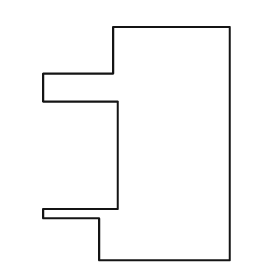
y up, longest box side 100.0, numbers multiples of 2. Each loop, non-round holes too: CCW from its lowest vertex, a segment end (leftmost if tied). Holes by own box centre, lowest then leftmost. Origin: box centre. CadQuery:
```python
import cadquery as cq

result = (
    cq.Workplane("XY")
    .moveTo(-16.0, -50.0)
    .lineTo(40.0, -50.0)
    .lineTo(40.0, 50.0)
    .lineTo(-10.0, 50.0)
    .lineTo(-10.0, 30.0)
    .lineTo(-40.0, 30.0)
    .lineTo(-40.0, 18.0)
    .lineTo(-8.0, 18.0)
    .lineTo(-8.0, -28.0)
    .lineTo(-40.0, -28.0)
    .lineTo(-40.0, -32.0)
    .lineTo(-16.0, -32.0)
    .close()
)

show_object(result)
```